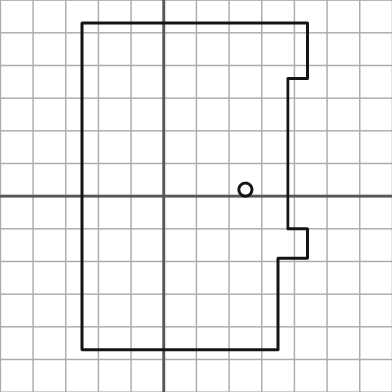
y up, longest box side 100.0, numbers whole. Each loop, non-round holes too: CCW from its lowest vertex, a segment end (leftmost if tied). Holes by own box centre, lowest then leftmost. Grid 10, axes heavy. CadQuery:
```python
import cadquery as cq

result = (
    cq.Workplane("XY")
    .moveTo(-25.0, -47.0)
    .lineTo(35.0, -47.0)
    .lineTo(35.0, -19.0)
    .lineTo(44.0, -19.0)
    .lineTo(44.0, -10.0)
    .lineTo(38.0, -10.0)
    .lineTo(38.0, 36.0)
    .lineTo(44.0, 36.0)
    .lineTo(44.0, 53.0)
    .lineTo(-25.0, 53.0)
    .close()
    .moveTo(25.0, 2.0)
    .circle(2.0)
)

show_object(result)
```